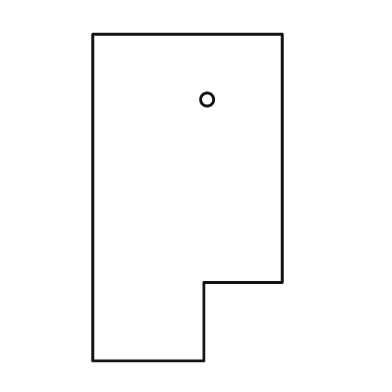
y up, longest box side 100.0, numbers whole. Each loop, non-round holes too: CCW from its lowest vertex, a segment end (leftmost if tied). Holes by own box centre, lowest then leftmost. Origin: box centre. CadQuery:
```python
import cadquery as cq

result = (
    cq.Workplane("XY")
    .moveTo(-29.0, -50.0)
    .lineTo(5.0, -50.0)
    .lineTo(5.0, -26.0)
    .lineTo(29.0, -26.0)
    .lineTo(29.0, 50.0)
    .lineTo(-29.0, 50.0)
    .close()
    .moveTo(6.0, 30.0)
    .circle(2.0)
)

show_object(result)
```